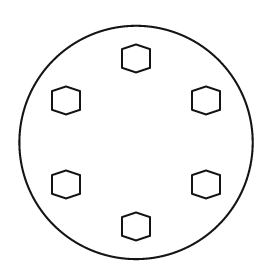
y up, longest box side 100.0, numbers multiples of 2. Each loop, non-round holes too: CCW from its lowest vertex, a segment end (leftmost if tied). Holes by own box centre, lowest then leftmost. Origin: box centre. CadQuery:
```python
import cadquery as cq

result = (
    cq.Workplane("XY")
    .moveTo(0.0, 0.0)
    .circle(50.0)
    .moveTo(0.0, -42.0)
    .lineTo(6.0, -40.0)
    .lineTo(6.0, -32.0)
    .lineTo(0.0, -30.0)
    .lineTo(-6.0, -32.0)
    .lineTo(-6.0, -40.0)
    .close()
    .moveTo(-30.0, -24.0)
    .lineTo(-24.0, -22.0)
    .lineTo(-24.0, -14.0)
    .lineTo(-30.0, -12.0)
    .lineTo(-36.0, -14.0)
    .lineTo(-36.0, -22.0)
    .close()
    .moveTo(30.0, -24.0)
    .lineTo(36.0, -22.0)
    .lineTo(36.0, -14.0)
    .lineTo(30.0, -12.0)
    .lineTo(24.0, -14.0)
    .lineTo(24.0, -22.0)
    .close()
    .moveTo(-30.0, 12.0)
    .lineTo(-24.0, 14.0)
    .lineTo(-24.0, 22.0)
    .lineTo(-30.0, 24.0)
    .lineTo(-36.0, 22.0)
    .lineTo(-36.0, 14.0)
    .close()
    .moveTo(30.0, 12.0)
    .lineTo(36.0, 14.0)
    .lineTo(36.0, 22.0)
    .lineTo(30.0, 24.0)
    .lineTo(24.0, 22.0)
    .lineTo(24.0, 14.0)
    .close()
    .moveTo(0.0, 30.0)
    .lineTo(6.0, 32.0)
    .lineTo(6.0, 40.0)
    .lineTo(0.0, 42.0)
    .lineTo(-6.0, 40.0)
    .lineTo(-6.0, 32.0)
    .close()
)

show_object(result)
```